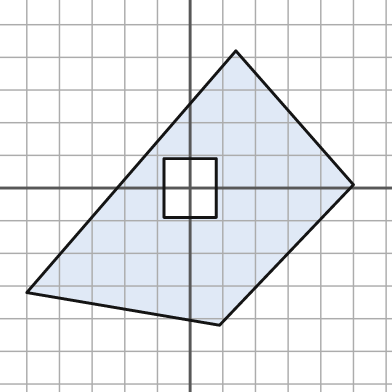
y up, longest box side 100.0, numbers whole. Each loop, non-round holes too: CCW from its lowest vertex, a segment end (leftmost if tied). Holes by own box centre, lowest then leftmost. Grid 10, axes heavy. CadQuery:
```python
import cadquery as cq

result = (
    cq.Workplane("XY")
    .moveTo(9.0, -42.0)
    .lineTo(50.0, 1.0)
    .lineTo(14.0, 42.0)
    .lineTo(-50.0, -32.0)
    .close()
    .moveTo(-8.0, -9.0)
    .lineTo(8.0, -9.0)
    .lineTo(8.0, 9.0)
    .lineTo(-8.0, 9.0)
    .close()
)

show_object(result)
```